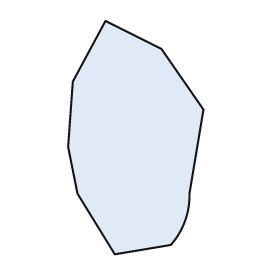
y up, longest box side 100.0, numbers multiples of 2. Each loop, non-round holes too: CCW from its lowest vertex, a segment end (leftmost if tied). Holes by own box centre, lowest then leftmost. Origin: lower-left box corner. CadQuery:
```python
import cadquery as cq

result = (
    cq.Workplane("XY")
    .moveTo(20.0, 0.0)
    .lineTo(44.0, 4.0)
    .threePointArc((50.0, 14.0), (52.0, 26.0))
    .lineTo(58.0, 62.0)
    .lineTo(40.0, 88.0)
    .lineTo(16.0, 100.0)
    .lineTo(2.0, 74.0)
    .lineTo(0.0, 46.0)
    .lineTo(4.0, 26.0)
    .close()
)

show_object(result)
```